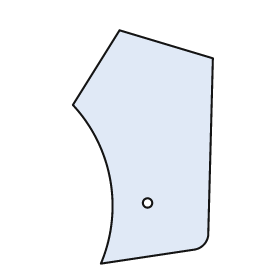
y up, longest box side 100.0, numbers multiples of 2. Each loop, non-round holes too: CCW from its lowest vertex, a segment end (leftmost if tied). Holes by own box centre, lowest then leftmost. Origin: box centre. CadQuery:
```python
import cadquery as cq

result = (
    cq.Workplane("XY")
    .moveTo(-18.0, -50.0)
    .lineTo(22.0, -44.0)
    .threePointArc((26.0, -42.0), (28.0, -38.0))
    .lineTo(30.0, 38.0)
    .lineTo(-10.0, 50.0)
    .lineTo(-30.0, 18.0)
    .threePointArc((-14.0, -14.0), (-18.0, -50.0))
    .close()
    .moveTo(2.0, -24.0)
    .circle(2.0)
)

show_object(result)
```